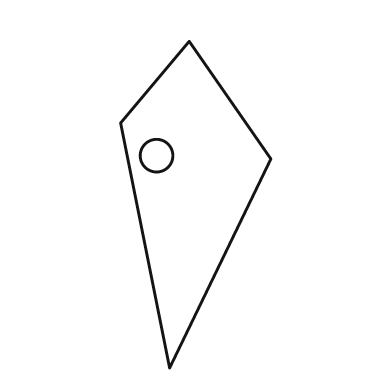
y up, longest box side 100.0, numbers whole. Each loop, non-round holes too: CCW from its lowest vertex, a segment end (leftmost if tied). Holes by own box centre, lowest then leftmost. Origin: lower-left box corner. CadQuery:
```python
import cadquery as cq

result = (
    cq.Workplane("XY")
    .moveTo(15.0, 0.0)
    .lineTo(46.0, 64.0)
    .lineTo(21.0, 100.0)
    .lineTo(0.0, 75.0)
    .close()
    .moveTo(11.0, 65.0)
    .circle(5.0)
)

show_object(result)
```